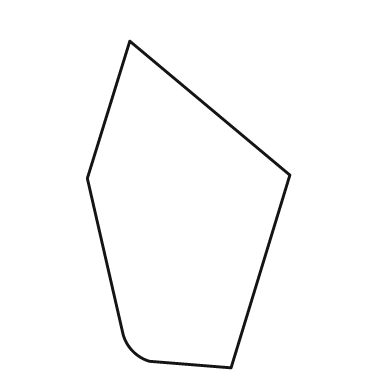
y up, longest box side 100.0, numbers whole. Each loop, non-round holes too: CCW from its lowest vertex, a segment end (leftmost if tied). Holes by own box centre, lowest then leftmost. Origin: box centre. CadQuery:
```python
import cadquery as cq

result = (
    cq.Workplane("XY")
    .moveTo(13.0, -50.0)
    .lineTo(31.0, 9.0)
    .lineTo(-18.0, 50.0)
    .lineTo(-31.0, 8.0)
    .lineTo(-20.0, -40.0)
    .threePointArc((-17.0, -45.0), (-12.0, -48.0))
    .close()
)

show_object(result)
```